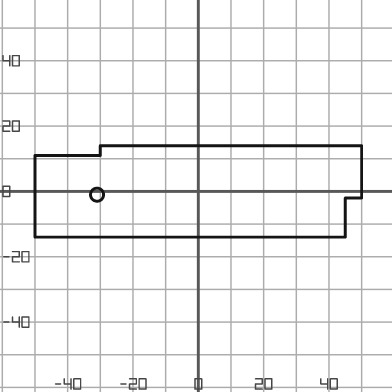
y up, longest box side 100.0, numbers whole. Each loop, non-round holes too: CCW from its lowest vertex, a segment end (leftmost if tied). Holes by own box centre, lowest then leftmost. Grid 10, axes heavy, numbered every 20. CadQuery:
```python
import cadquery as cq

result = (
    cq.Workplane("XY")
    .moveTo(-50.0, -14.0)
    .lineTo(45.0, -14.0)
    .lineTo(45.0, -2.0)
    .lineTo(50.0, -2.0)
    .lineTo(50.0, 14.0)
    .lineTo(-30.0, 14.0)
    .lineTo(-30.0, 11.0)
    .lineTo(-50.0, 11.0)
    .close()
    .moveTo(-31.0, -1.0)
    .circle(2.0)
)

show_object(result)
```